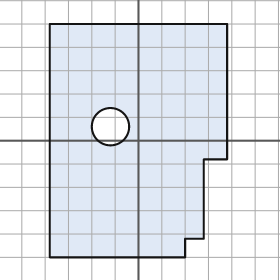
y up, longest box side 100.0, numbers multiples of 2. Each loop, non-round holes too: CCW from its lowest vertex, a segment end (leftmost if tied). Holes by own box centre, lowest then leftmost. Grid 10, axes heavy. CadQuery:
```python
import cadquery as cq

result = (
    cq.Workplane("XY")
    .moveTo(-38.0, -50.0)
    .lineTo(20.0, -50.0)
    .lineTo(20.0, -42.0)
    .lineTo(28.0, -42.0)
    .lineTo(28.0, -8.0)
    .lineTo(38.0, -8.0)
    .lineTo(38.0, 50.0)
    .lineTo(-38.0, 50.0)
    .close()
    .moveTo(-12.0, 6.0)
    .circle(8.0)
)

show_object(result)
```